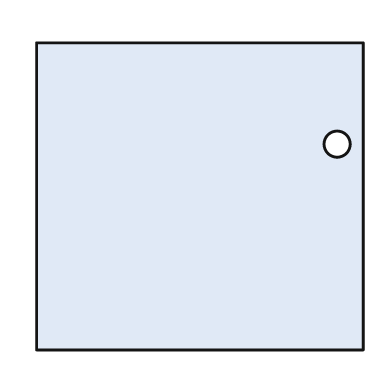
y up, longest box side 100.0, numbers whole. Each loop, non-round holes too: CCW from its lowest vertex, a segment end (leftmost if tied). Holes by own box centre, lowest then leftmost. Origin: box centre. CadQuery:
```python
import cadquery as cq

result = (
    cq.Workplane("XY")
    .moveTo(-50.0, -47.0)
    .lineTo(50.0, -47.0)
    .lineTo(50.0, 47.0)
    .lineTo(-50.0, 47.0)
    .close()
    .moveTo(42.0, 16.0)
    .circle(4.0)
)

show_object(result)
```